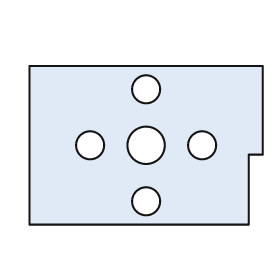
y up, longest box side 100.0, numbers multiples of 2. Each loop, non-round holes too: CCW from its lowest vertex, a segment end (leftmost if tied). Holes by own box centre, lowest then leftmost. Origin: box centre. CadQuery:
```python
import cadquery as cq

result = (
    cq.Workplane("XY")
    .moveTo(-50.0, -34.0)
    .lineTo(44.0, -34.0)
    .lineTo(44.0, -4.0)
    .lineTo(50.0, -4.0)
    .lineTo(50.0, 34.0)
    .lineTo(-50.0, 34.0)
    .close()
    .moveTo(0.0, -24.0)
    .circle(6.0)
    .moveTo(-24.0, 0.0)
    .circle(6.0)
    .moveTo(0.0, 0.0)
    .circle(8.0)
    .moveTo(24.0, 0.0)
    .circle(6.0)
    .moveTo(0.0, 24.0)
    .circle(6.0)
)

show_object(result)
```